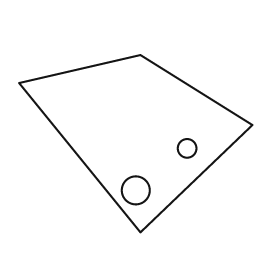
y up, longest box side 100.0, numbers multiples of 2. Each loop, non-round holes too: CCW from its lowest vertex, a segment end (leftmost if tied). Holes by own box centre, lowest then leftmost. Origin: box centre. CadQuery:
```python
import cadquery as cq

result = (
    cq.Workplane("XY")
    .moveTo(2.0, -38.0)
    .lineTo(50.0, 8.0)
    .lineTo(2.0, 38.0)
    .lineTo(-50.0, 26.0)
    .close()
    .moveTo(0.0, -20.0)
    .circle(6.0)
    .moveTo(22.0, -2.0)
    .circle(4.0)
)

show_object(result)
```